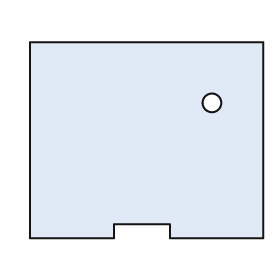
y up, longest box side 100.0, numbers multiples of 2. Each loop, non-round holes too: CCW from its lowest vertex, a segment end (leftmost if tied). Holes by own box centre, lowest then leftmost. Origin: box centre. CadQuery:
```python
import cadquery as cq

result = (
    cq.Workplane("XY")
    .moveTo(-50.0, -42.0)
    .lineTo(-14.0, -42.0)
    .lineTo(-14.0, -36.0)
    .lineTo(10.0, -36.0)
    .lineTo(10.0, -42.0)
    .lineTo(50.0, -42.0)
    .lineTo(50.0, 42.0)
    .lineTo(-50.0, 42.0)
    .close()
    .moveTo(28.0, 16.0)
    .circle(4.0)
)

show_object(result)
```